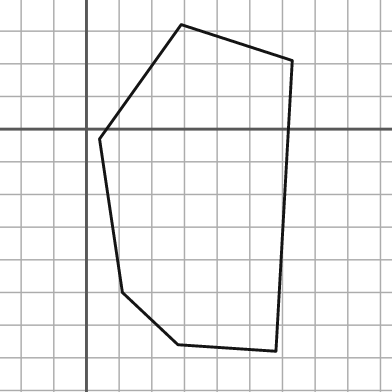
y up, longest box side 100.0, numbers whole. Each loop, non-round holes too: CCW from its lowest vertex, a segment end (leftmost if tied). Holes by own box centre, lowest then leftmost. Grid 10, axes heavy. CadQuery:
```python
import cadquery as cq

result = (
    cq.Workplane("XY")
    .moveTo(58.0, -68.0)
    .lineTo(63.0, 21.0)
    .lineTo(29.0, 32.0)
    .lineTo(4.0, -3.0)
    .lineTo(11.0, -50.0)
    .lineTo(28.0, -66.0)
    .close()
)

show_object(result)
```